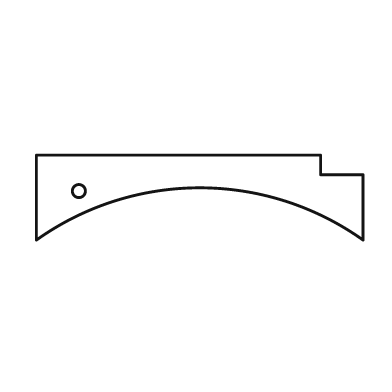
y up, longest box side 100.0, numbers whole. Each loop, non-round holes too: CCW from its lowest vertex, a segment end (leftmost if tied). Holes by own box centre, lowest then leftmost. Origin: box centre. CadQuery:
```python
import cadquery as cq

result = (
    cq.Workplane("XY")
    .moveTo(-50.0, -13.0)
    .threePointArc((0.0, 3.0), (50.0, -13.0))
    .lineTo(50.0, 7.0)
    .lineTo(37.0, 7.0)
    .lineTo(37.0, 13.0)
    .lineTo(-50.0, 13.0)
    .close()
    .moveTo(-37.0, 2.0)
    .circle(2.0)
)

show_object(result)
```